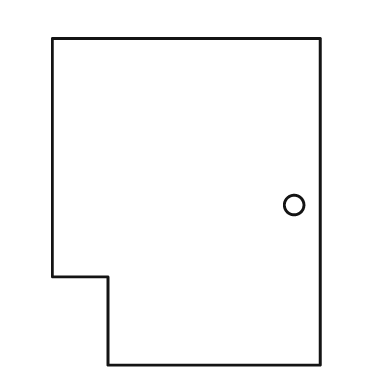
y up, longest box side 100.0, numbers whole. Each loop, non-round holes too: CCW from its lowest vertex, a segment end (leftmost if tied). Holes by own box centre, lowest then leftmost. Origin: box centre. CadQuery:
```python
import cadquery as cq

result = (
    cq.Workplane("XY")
    .moveTo(-24.0, -50.0)
    .lineTo(41.0, -50.0)
    .lineTo(41.0, 50.0)
    .lineTo(-41.0, 50.0)
    .lineTo(-41.0, -23.0)
    .lineTo(-24.0, -23.0)
    .close()
    .moveTo(33.0, -1.0)
    .circle(3.0)
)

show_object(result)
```